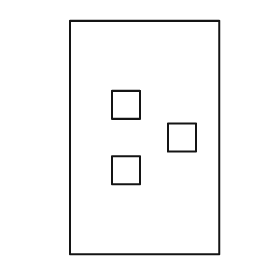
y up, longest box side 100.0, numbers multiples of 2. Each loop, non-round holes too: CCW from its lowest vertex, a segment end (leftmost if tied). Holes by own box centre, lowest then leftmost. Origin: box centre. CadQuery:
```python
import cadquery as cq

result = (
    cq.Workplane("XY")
    .moveTo(-32.0, -50.0)
    .lineTo(32.0, -50.0)
    .lineTo(32.0, 50.0)
    .lineTo(-32.0, 50.0)
    .close()
    .moveTo(-14.0, -20.0)
    .lineTo(-2.0, -20.0)
    .lineTo(-2.0, -8.0)
    .lineTo(-14.0, -8.0)
    .close()
    .moveTo(10.0, -6.0)
    .lineTo(22.0, -6.0)
    .lineTo(22.0, 6.0)
    .lineTo(10.0, 6.0)
    .close()
    .moveTo(-14.0, 8.0)
    .lineTo(-2.0, 8.0)
    .lineTo(-2.0, 20.0)
    .lineTo(-14.0, 20.0)
    .close()
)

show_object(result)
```